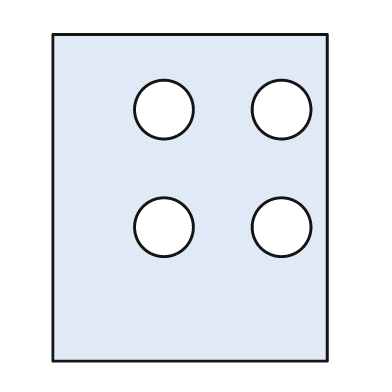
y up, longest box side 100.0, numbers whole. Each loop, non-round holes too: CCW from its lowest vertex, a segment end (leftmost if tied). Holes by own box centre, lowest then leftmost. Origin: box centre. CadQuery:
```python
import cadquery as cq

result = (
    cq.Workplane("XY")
    .moveTo(-42.0, -50.0)
    .lineTo(42.0, -50.0)
    .lineTo(42.0, 50.0)
    .lineTo(-42.0, 50.0)
    .close()
    .moveTo(-8.0, -9.0)
    .circle(9.0)
    .moveTo(28.0, -9.0)
    .circle(9.0)
    .moveTo(-8.0, 27.0)
    .circle(9.0)
    .moveTo(28.0, 27.0)
    .circle(9.0)
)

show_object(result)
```